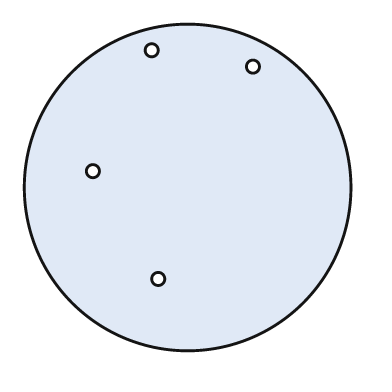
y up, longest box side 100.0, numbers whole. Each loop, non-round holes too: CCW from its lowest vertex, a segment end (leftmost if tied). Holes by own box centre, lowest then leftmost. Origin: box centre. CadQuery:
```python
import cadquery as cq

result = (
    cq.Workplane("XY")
    .moveTo(0.0, 0.0)
    .circle(50.0)
    .moveTo(-9.0, -28.0)
    .circle(2.0)
    .moveTo(-29.0, 5.0)
    .circle(2.0)
    .moveTo(20.0, 37.0)
    .circle(2.0)
    .moveTo(-11.0, 42.0)
    .circle(2.0)
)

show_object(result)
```